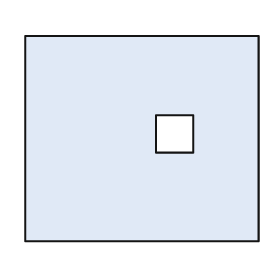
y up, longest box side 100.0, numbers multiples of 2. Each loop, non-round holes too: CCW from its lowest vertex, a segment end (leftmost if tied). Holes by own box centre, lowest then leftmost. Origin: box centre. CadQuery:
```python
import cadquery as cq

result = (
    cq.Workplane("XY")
    .moveTo(-50.0, -44.0)
    .lineTo(50.0, -44.0)
    .lineTo(50.0, 44.0)
    .lineTo(-50.0, 44.0)
    .close()
    .moveTo(6.0, -6.0)
    .lineTo(22.0, -6.0)
    .lineTo(22.0, 10.0)
    .lineTo(6.0, 10.0)
    .close()
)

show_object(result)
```